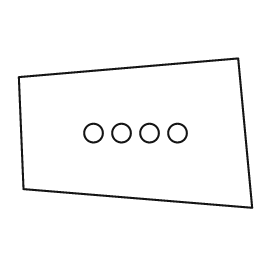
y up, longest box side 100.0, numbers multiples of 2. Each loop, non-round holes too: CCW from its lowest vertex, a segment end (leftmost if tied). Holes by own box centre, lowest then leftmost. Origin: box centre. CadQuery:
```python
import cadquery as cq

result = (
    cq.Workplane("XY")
    .moveTo(50.0, -32.0)
    .lineTo(44.0, 32.0)
    .lineTo(-50.0, 24.0)
    .lineTo(-48.0, -24.0)
    .close()
    .moveTo(-18.0, 0.0)
    .circle(4.0)
    .moveTo(-6.0, 0.0)
    .circle(4.0)
    .moveTo(6.0, 0.0)
    .circle(4.0)
    .moveTo(18.0, 0.0)
    .circle(4.0)
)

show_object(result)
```